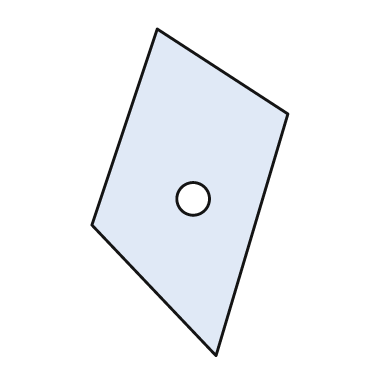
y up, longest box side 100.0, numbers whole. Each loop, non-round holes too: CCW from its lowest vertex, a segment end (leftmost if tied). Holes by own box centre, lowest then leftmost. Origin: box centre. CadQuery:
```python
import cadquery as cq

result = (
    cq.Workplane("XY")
    .moveTo(8.0, -50.0)
    .lineTo(30.0, 24.0)
    .lineTo(-10.0, 50.0)
    .lineTo(-30.0, -10.0)
    .close()
    .moveTo(1.0, -2.0)
    .circle(5.0)
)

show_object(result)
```